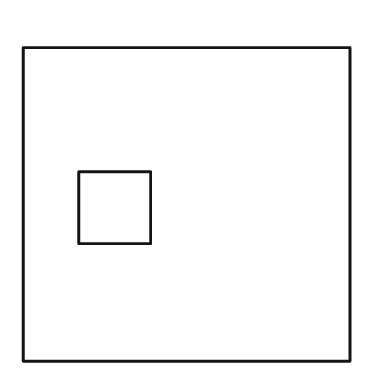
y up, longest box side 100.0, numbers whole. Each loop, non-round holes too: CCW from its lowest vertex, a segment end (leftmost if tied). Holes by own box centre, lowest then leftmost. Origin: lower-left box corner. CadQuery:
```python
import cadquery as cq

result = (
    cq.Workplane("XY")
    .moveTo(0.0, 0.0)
    .lineTo(100.0, 0.0)
    .lineTo(100.0, 96.0)
    .lineTo(0.0, 96.0)
    .close()
    .moveTo(17.0, 36.0)
    .lineTo(39.0, 36.0)
    .lineTo(39.0, 58.0)
    .lineTo(17.0, 58.0)
    .close()
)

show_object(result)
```